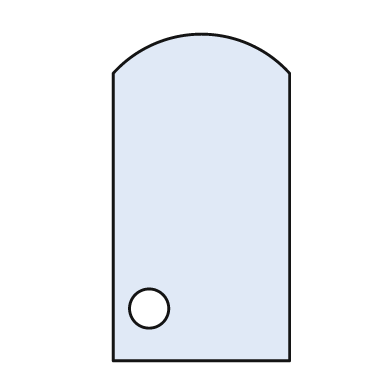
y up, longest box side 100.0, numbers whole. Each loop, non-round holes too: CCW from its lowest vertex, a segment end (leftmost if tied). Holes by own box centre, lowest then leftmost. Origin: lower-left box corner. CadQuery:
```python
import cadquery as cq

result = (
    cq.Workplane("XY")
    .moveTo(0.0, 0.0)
    .lineTo(54.0, 0.0)
    .lineTo(54.0, 88.0)
    .threePointArc((27.0, 100.0), (0.0, 88.0))
    .close()
    .moveTo(11.0, 16.0)
    .circle(6.0)
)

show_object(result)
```